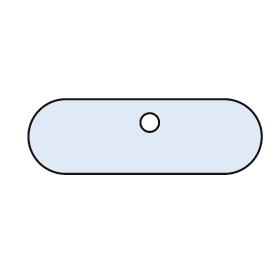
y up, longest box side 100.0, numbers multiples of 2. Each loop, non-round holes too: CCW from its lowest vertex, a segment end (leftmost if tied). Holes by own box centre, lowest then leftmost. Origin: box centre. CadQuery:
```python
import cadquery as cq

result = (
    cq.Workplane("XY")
    .moveTo(-34.0, -16.0)
    .lineTo(34.0, -16.0)
    .threePointArc((50.0, 0.0), (34.0, 16.0))
    .lineTo(-34.0, 16.0)
    .threePointArc((-50.0, 0.0), (-34.0, -16.0))
    .close()
    .moveTo(2.0, 6.0)
    .circle(4.0)
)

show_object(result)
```